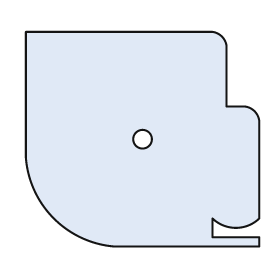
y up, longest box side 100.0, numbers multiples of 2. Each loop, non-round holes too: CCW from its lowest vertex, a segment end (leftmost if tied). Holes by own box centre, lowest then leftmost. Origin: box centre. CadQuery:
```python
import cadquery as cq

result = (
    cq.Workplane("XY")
    .moveTo(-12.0, -46.0)
    .lineTo(50.0, -46.0)
    .lineTo(50.0, -42.0)
    .lineTo(30.0, -42.0)
    .lineTo(30.0, -34.0)
    .threePointArc((40.0, -38.0), (50.0, -34.0))
    .lineTo(50.0, 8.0)
    .threePointArc((48.0, 12.0), (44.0, 14.0))
    .lineTo(36.0, 14.0)
    .lineTo(36.0, 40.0)
    .threePointArc((34.0, 44.0), (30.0, 46.0))
    .lineTo(-50.0, 46.0)
    .lineTo(-50.0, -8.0)
    .threePointArc((-38.0, -34.0), (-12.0, -46.0))
    .close()
    .moveTo(0.0, 0.0)
    .circle(4.0)
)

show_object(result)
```